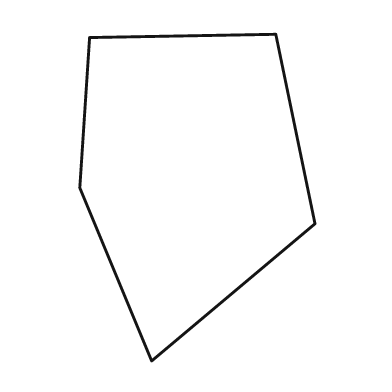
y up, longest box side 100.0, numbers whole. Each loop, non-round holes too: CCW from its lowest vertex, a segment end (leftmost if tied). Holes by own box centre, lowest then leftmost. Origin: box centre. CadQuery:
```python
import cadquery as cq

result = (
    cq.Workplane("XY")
    .moveTo(-14.0, -50.0)
    .lineTo(36.0, -8.0)
    .lineTo(24.0, 50.0)
    .lineTo(-33.0, 49.0)
    .lineTo(-36.0, 3.0)
    .close()
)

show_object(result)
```